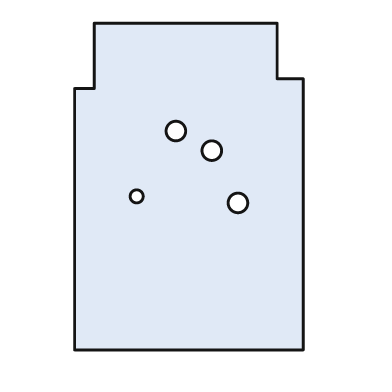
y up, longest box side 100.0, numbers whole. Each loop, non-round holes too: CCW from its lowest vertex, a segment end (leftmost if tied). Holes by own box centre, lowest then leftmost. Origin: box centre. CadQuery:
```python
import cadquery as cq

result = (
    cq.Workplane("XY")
    .moveTo(-35.0, -50.0)
    .lineTo(35.0, -50.0)
    .lineTo(35.0, 33.0)
    .lineTo(27.0, 33.0)
    .lineTo(27.0, 50.0)
    .lineTo(-29.0, 50.0)
    .lineTo(-29.0, 30.0)
    .lineTo(-35.0, 30.0)
    .close()
    .moveTo(15.0, -5.0)
    .circle(3.0)
    .moveTo(-16.0, -3.0)
    .circle(2.0)
    .moveTo(7.0, 11.0)
    .circle(3.0)
    .moveTo(-4.0, 17.0)
    .circle(3.0)
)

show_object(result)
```